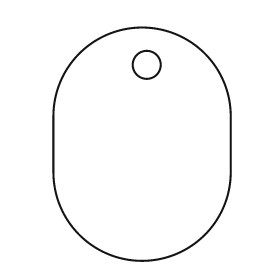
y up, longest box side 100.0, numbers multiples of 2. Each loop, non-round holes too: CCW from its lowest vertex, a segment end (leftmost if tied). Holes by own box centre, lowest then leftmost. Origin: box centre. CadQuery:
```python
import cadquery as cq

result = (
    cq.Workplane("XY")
    .moveTo(-38.0, -12.0)
    .threePointArc((0.0, -50.0), (38.0, -12.0))
    .lineTo(38.0, 12.0)
    .threePointArc((0.0, 50.0), (-38.0, 12.0))
    .close()
    .moveTo(2.0, 34.0)
    .circle(6.0)
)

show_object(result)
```